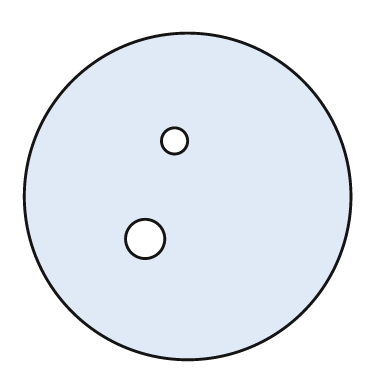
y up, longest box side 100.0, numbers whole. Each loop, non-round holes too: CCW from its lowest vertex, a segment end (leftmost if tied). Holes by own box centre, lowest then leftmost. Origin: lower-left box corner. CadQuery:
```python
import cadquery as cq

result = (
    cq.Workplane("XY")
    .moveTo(50.0, 50.0)
    .circle(50.0)
    .moveTo(37.0, 37.0)
    .circle(6.0)
    .moveTo(46.0, 67.0)
    .circle(4.0)
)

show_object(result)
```